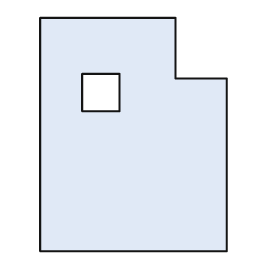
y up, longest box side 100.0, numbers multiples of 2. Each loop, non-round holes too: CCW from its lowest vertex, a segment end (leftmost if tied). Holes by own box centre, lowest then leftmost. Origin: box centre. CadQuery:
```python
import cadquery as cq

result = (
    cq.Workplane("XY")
    .moveTo(-40.0, -50.0)
    .lineTo(40.0, -50.0)
    .lineTo(40.0, 24.0)
    .lineTo(18.0, 24.0)
    .lineTo(18.0, 50.0)
    .lineTo(-40.0, 50.0)
    .close()
    .moveTo(-22.0, 10.0)
    .lineTo(-6.0, 10.0)
    .lineTo(-6.0, 26.0)
    .lineTo(-22.0, 26.0)
    .close()
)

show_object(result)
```